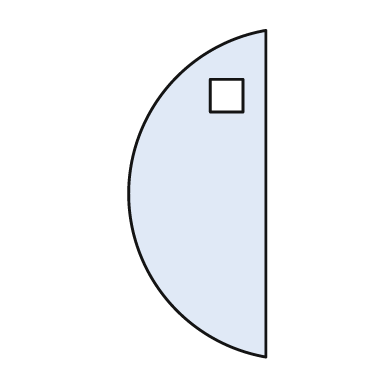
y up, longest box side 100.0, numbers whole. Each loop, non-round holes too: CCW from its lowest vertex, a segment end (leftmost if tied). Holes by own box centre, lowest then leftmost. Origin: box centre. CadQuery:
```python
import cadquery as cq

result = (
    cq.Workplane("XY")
    .moveTo(21.0, -50.0)
    .lineTo(21.0, 50.0)
    .threePointArc((-21.0, 0.0), (21.0, -50.0))
    .close()
    .moveTo(4.0, 25.0)
    .lineTo(14.0, 25.0)
    .lineTo(14.0, 35.0)
    .lineTo(4.0, 35.0)
    .close()
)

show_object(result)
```